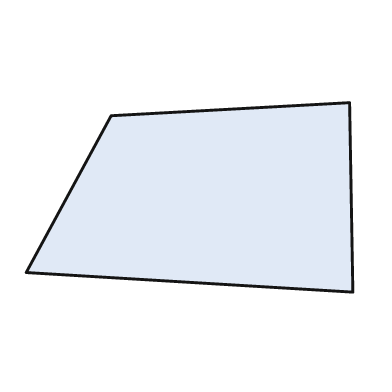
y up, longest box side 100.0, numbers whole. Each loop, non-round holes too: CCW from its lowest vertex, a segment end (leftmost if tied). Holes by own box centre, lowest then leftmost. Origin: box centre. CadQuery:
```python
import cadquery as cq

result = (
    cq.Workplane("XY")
    .moveTo(50.0, -29.0)
    .lineTo(49.0, 29.0)
    .lineTo(-24.0, 25.0)
    .lineTo(-50.0, -23.0)
    .close()
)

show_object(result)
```